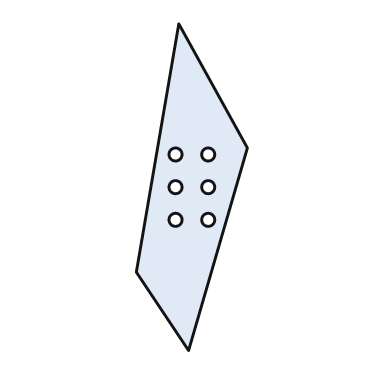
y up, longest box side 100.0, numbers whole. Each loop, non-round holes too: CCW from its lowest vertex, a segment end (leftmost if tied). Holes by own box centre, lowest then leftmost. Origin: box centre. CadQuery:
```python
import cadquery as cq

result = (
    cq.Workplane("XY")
    .moveTo(-1.0, -50.0)
    .lineTo(17.0, 12.0)
    .lineTo(-4.0, 50.0)
    .lineTo(-17.0, -26.0)
    .close()
    .moveTo(-5.0, -10.0)
    .circle(2.0)
    .moveTo(5.0, -10.0)
    .circle(2.0)
    .moveTo(-5.0, 0.0)
    .circle(2.0)
    .moveTo(5.0, 0.0)
    .circle(2.0)
    .moveTo(-5.0, 10.0)
    .circle(2.0)
    .moveTo(5.0, 10.0)
    .circle(2.0)
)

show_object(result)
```